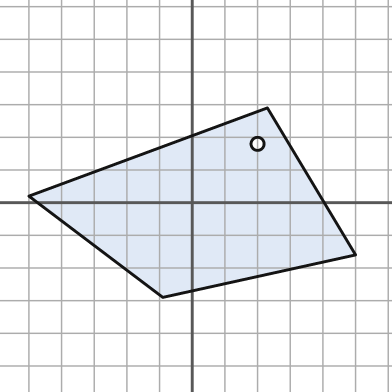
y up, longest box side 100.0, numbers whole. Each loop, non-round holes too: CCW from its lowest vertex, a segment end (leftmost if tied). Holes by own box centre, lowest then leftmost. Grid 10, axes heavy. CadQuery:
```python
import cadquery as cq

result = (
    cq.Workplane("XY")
    .moveTo(-9.0, -29.0)
    .lineTo(50.0, -16.0)
    .lineTo(23.0, 29.0)
    .lineTo(-50.0, 2.0)
    .close()
    .moveTo(20.0, 18.0)
    .circle(2.0)
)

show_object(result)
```